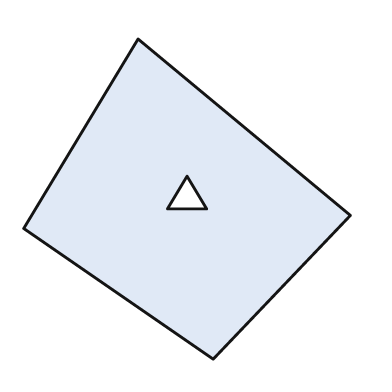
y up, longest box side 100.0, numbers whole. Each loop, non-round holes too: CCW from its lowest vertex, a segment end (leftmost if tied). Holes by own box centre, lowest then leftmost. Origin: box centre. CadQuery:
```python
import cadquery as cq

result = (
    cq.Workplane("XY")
    .moveTo(8.0, -49.0)
    .lineTo(50.0, -5.0)
    .lineTo(-15.0, 49.0)
    .lineTo(-50.0, -9.0)
    .close()
    .moveTo(-6.0, -3.0)
    .lineTo(6.0, -3.0)
    .lineTo(0.0, 7.0)
    .close()
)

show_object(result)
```